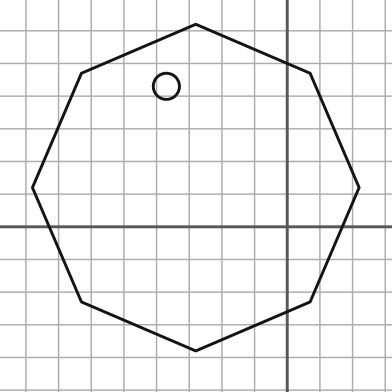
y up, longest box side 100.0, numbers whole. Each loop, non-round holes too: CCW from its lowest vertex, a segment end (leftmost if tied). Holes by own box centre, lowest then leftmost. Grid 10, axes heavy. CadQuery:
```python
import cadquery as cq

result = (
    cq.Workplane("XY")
    .moveTo(-28.0, -38.0)
    .lineTo(7.0, -23.0)
    .lineTo(22.0, 12.0)
    .lineTo(7.0, 47.0)
    .lineTo(-28.0, 62.0)
    .lineTo(-63.0, 47.0)
    .lineTo(-78.0, 12.0)
    .lineTo(-63.0, -23.0)
    .close()
    .moveTo(-37.0, 43.0)
    .circle(4.0)
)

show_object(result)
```